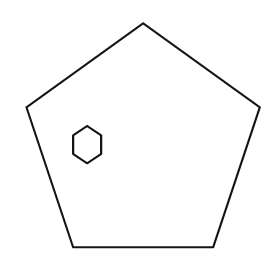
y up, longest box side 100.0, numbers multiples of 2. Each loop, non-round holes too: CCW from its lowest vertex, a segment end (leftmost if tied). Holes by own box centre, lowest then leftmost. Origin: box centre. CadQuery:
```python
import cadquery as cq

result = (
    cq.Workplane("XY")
    .moveTo(-30.0, -48.0)
    .lineTo(30.0, -48.0)
    .lineTo(50.0, 12.0)
    .lineTo(0.0, 48.0)
    .lineTo(-50.0, 12.0)
    .close()
    .moveTo(-24.0, -12.0)
    .lineTo(-18.0, -8.0)
    .lineTo(-18.0, 0.0)
    .lineTo(-24.0, 4.0)
    .lineTo(-30.0, 0.0)
    .lineTo(-30.0, -8.0)
    .close()
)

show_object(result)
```